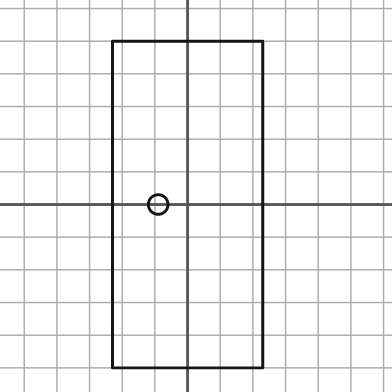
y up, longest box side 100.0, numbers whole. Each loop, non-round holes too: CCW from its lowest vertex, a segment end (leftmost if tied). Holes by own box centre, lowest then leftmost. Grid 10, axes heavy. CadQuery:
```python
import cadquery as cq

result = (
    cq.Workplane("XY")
    .moveTo(-23.0, -50.0)
    .lineTo(23.0, -50.0)
    .lineTo(23.0, 50.0)
    .lineTo(-23.0, 50.0)
    .close()
    .moveTo(-9.0, 0.0)
    .circle(3.0)
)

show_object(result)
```